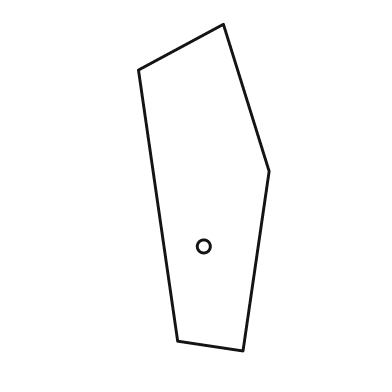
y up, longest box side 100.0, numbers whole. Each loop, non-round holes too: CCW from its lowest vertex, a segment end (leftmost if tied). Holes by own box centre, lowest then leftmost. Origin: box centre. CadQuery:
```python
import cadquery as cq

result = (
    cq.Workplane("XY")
    .moveTo(12.0, -50.0)
    .lineTo(20.0, 5.0)
    .lineTo(6.0, 50.0)
    .lineTo(-20.0, 36.0)
    .lineTo(-8.0, -47.0)
    .close()
    .moveTo(0.0, -18.0)
    .circle(2.0)
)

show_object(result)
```